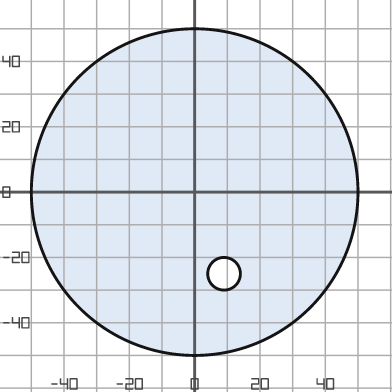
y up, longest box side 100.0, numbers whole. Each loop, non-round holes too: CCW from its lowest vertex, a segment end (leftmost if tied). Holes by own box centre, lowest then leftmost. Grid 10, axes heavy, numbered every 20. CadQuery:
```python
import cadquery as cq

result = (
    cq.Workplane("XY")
    .moveTo(0.0, 0.0)
    .circle(50.0)
    .moveTo(9.0, -25.0)
    .circle(5.0)
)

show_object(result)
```